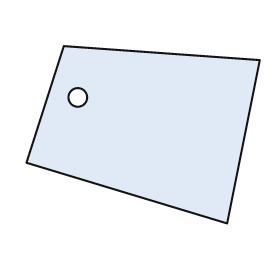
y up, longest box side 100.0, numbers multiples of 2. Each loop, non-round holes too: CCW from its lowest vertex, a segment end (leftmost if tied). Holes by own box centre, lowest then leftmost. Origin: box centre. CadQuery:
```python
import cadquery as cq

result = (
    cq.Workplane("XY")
    .moveTo(36.0, -38.0)
    .lineTo(50.0, 32.0)
    .lineTo(-34.0, 38.0)
    .lineTo(-50.0, -12.0)
    .close()
    .moveTo(-28.0, 16.0)
    .circle(4.0)
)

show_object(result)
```